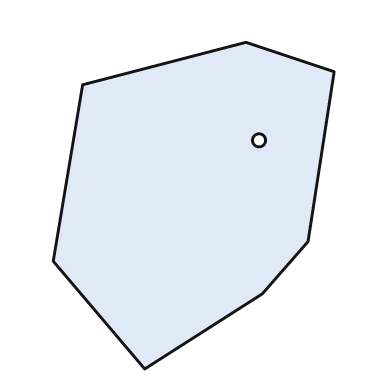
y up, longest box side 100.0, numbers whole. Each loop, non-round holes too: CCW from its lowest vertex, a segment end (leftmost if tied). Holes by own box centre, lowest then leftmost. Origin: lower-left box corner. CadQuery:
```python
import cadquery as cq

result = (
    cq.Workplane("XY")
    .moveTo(28.0, 0.0)
    .lineTo(64.0, 23.0)
    .lineTo(78.0, 39.0)
    .lineTo(86.0, 91.0)
    .lineTo(59.0, 100.0)
    .lineTo(9.0, 87.0)
    .lineTo(0.0, 33.0)
    .close()
    .moveTo(63.0, 70.0)
    .circle(2.0)
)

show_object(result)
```